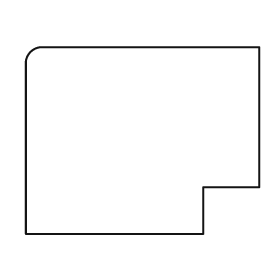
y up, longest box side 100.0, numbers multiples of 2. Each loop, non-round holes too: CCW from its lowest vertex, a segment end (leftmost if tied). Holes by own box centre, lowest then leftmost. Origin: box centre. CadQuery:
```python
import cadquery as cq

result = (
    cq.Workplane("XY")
    .moveTo(-50.0, -40.0)
    .lineTo(26.0, -40.0)
    .lineTo(26.0, -20.0)
    .lineTo(50.0, -20.0)
    .lineTo(50.0, 40.0)
    .lineTo(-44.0, 40.0)
    .threePointArc((-48.0, 38.0), (-50.0, 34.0))
    .close()
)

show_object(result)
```